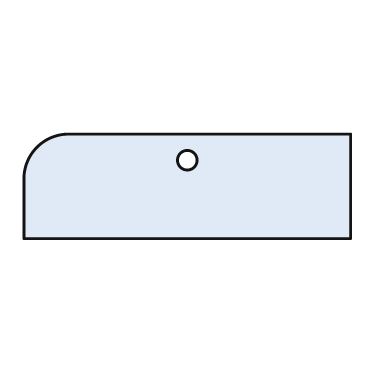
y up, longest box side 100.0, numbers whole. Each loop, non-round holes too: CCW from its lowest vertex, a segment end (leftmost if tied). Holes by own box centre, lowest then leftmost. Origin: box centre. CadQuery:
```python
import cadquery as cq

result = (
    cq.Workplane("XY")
    .moveTo(-50.0, -16.0)
    .lineTo(50.0, -16.0)
    .lineTo(50.0, 16.0)
    .lineTo(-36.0, 16.0)
    .threePointArc((-46.0, 12.0), (-50.0, 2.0))
    .close()
    .moveTo(0.0, 8.0)
    .circle(3.0)
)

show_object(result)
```